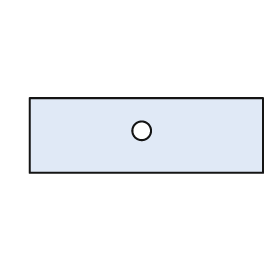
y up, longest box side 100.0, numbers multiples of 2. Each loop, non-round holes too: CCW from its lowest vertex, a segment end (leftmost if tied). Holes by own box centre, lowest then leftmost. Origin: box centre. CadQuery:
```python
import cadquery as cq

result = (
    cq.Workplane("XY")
    .moveTo(-50.0, -16.0)
    .lineTo(50.0, -16.0)
    .lineTo(50.0, 16.0)
    .lineTo(-50.0, 16.0)
    .close()
    .moveTo(-2.0, 2.0)
    .circle(4.0)
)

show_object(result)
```